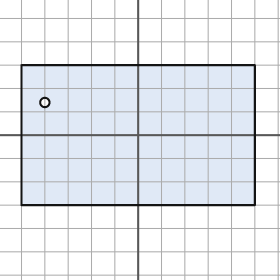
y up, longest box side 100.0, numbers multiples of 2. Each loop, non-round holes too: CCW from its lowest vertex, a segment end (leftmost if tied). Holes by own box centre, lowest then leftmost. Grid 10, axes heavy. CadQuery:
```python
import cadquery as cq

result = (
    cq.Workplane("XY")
    .moveTo(-50.0, -30.0)
    .lineTo(50.0, -30.0)
    .lineTo(50.0, 30.0)
    .lineTo(-50.0, 30.0)
    .close()
    .moveTo(-40.0, 14.0)
    .circle(2.0)
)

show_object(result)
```